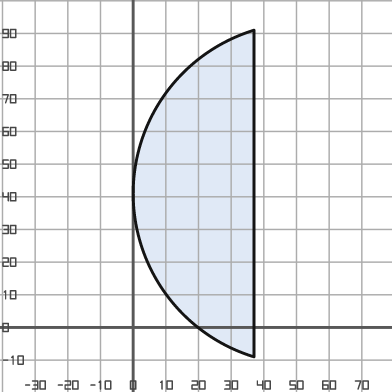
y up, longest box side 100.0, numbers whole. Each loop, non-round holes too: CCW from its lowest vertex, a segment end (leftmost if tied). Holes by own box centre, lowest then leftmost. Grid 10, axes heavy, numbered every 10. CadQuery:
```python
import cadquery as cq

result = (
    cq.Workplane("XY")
    .moveTo(37.0, -9.0)
    .lineTo(37.0, 91.0)
    .threePointArc((0.0, 41.0), (37.0, -9.0))
    .close()
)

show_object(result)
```